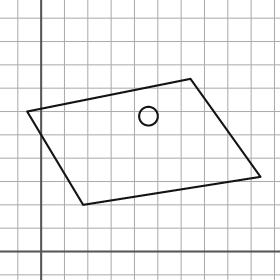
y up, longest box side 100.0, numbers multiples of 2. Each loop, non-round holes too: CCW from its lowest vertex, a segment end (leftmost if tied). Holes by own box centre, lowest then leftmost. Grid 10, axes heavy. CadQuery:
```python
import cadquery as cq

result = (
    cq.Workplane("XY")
    .moveTo(18.0, 20.0)
    .lineTo(94.0, 32.0)
    .lineTo(64.0, 74.0)
    .lineTo(-6.0, 60.0)
    .close()
    .moveTo(46.0, 58.0)
    .circle(4.0)
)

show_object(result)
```